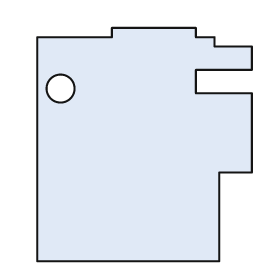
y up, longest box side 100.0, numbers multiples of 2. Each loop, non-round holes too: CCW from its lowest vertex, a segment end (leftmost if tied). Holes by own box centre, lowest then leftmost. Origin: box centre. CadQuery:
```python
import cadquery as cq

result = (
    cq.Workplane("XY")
    .moveTo(-46.0, -50.0)
    .lineTo(32.0, -50.0)
    .lineTo(32.0, -12.0)
    .lineTo(46.0, -12.0)
    .lineTo(46.0, 22.0)
    .lineTo(22.0, 22.0)
    .lineTo(22.0, 32.0)
    .lineTo(46.0, 32.0)
    .lineTo(46.0, 42.0)
    .lineTo(30.0, 42.0)
    .lineTo(30.0, 46.0)
    .lineTo(22.0, 46.0)
    .lineTo(22.0, 50.0)
    .lineTo(-14.0, 50.0)
    .lineTo(-14.0, 46.0)
    .lineTo(-46.0, 46.0)
    .close()
    .moveTo(-36.0, 24.0)
    .circle(6.0)
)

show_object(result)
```